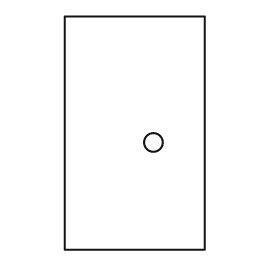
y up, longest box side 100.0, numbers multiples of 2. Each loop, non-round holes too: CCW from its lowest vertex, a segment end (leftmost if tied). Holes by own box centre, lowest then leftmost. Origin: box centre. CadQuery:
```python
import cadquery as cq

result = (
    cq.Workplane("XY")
    .moveTo(-30.0, -50.0)
    .lineTo(30.0, -50.0)
    .lineTo(30.0, 50.0)
    .lineTo(-30.0, 50.0)
    .close()
    .moveTo(8.0, -4.0)
    .circle(4.0)
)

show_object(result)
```